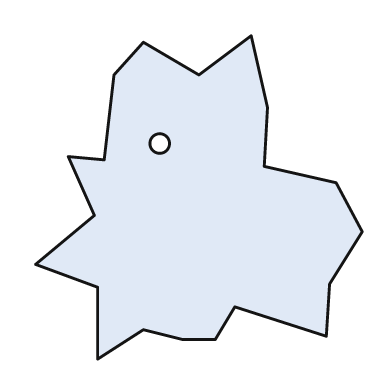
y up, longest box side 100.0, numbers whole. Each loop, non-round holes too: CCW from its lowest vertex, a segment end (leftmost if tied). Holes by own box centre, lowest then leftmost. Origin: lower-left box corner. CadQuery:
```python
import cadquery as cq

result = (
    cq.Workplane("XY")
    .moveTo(19.0, 0.0)
    .lineTo(33.0, 9.0)
    .lineTo(45.0, 6.0)
    .lineTo(55.0, 6.0)
    .lineTo(61.0, 16.0)
    .lineTo(89.0, 7.0)
    .lineTo(90.0, 23.0)
    .lineTo(100.0, 39.0)
    .lineTo(92.0, 54.0)
    .lineTo(70.0, 59.0)
    .lineTo(71.0, 77.0)
    .lineTo(66.0, 99.0)
    .lineTo(50.0, 87.0)
    .lineTo(33.0, 97.0)
    .lineTo(24.0, 87.0)
    .lineTo(21.0, 61.0)
    .lineTo(10.0, 62.0)
    .lineTo(18.0, 44.0)
    .lineTo(0.0, 29.0)
    .lineTo(19.0, 22.0)
    .close()
    .moveTo(38.0, 66.0)
    .circle(3.0)
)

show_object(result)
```